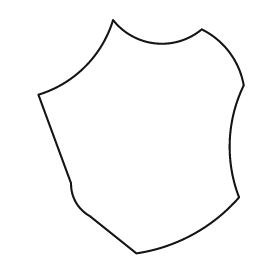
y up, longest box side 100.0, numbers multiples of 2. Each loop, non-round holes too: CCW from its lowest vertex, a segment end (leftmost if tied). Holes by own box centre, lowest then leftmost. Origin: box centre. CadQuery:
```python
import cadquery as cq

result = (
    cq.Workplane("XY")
    .moveTo(-2.0, -50.0)
    .threePointArc((22.0, -42.0), (42.0, -26.0))
    .threePointArc((38.0, -2.0), (44.0, 22.0))
    .threePointArc((38.0, 36.0), (26.0, 46.0))
    .threePointArc((6.0, 40.0), (-12.0, 50.0))
    .threePointArc((-24.0, 30.0), (-44.0, 18.0))
    .lineTo(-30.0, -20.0)
    .threePointArc((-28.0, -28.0), (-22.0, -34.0))
    .close()
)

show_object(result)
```